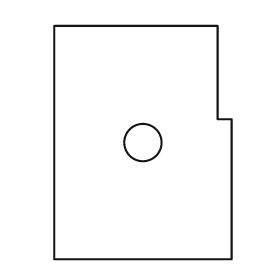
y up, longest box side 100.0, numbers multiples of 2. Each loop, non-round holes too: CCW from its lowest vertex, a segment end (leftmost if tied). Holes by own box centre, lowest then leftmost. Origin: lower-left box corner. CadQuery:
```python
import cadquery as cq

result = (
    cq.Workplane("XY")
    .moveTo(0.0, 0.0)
    .lineTo(76.0, 0.0)
    .lineTo(76.0, 60.0)
    .lineTo(70.0, 60.0)
    .lineTo(70.0, 100.0)
    .lineTo(0.0, 100.0)
    .close()
    .moveTo(38.0, 50.0)
    .circle(8.0)
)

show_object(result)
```